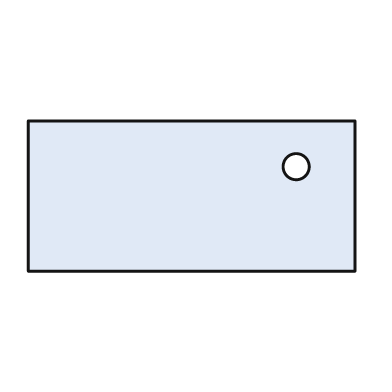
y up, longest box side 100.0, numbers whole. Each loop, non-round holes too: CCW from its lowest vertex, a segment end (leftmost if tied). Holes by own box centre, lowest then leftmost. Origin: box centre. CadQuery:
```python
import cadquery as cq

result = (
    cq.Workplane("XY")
    .moveTo(-50.0, -23.0)
    .lineTo(50.0, -23.0)
    .lineTo(50.0, 23.0)
    .lineTo(-50.0, 23.0)
    .close()
    .moveTo(32.0, 9.0)
    .circle(4.0)
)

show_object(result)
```